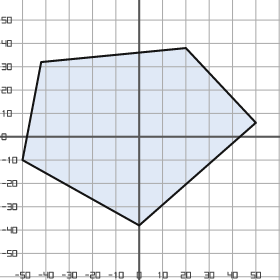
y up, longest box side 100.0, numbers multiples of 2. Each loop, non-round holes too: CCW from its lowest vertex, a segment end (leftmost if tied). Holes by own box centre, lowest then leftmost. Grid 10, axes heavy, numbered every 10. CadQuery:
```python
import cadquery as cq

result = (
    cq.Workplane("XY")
    .moveTo(0.0, -38.0)
    .lineTo(50.0, 6.0)
    .lineTo(20.0, 38.0)
    .lineTo(-42.0, 32.0)
    .lineTo(-50.0, -10.0)
    .close()
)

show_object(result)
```